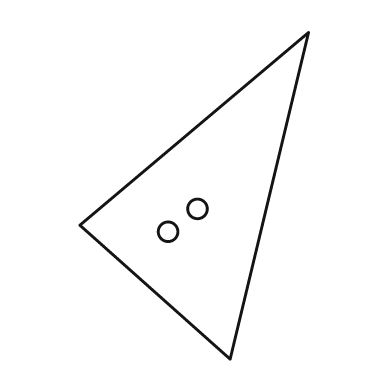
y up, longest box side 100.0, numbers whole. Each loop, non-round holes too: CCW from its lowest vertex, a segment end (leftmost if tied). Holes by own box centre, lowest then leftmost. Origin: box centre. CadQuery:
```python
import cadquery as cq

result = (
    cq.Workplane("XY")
    .moveTo(11.0, -50.0)
    .lineTo(35.0, 50.0)
    .lineTo(-35.0, -9.0)
    .close()
    .moveTo(-8.0, -11.0)
    .circle(3.0)
    .moveTo(1.0, -4.0)
    .circle(3.0)
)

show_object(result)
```